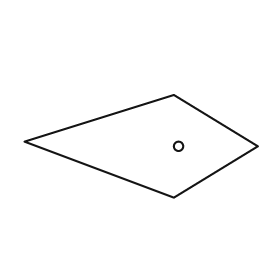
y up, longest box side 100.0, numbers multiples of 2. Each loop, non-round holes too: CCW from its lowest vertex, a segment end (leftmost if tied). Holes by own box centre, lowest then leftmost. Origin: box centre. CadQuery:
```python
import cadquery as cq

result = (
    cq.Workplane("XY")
    .moveTo(14.0, -22.0)
    .lineTo(50.0, 0.0)
    .lineTo(14.0, 22.0)
    .lineTo(-50.0, 2.0)
    .close()
    .moveTo(16.0, 0.0)
    .circle(2.0)
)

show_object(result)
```